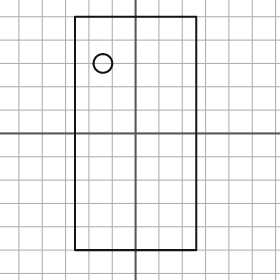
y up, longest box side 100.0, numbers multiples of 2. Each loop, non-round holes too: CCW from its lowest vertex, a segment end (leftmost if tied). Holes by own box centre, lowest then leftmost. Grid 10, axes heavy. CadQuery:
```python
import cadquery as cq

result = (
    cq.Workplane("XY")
    .moveTo(-26.0, -50.0)
    .lineTo(26.0, -50.0)
    .lineTo(26.0, 50.0)
    .lineTo(-26.0, 50.0)
    .close()
    .moveTo(-14.0, 30.0)
    .circle(4.0)
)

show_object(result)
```